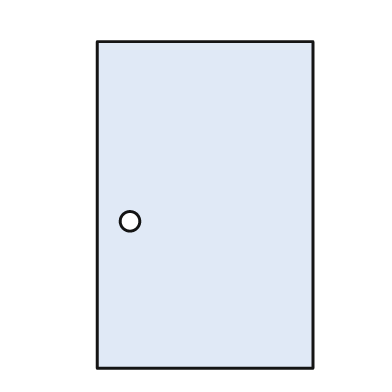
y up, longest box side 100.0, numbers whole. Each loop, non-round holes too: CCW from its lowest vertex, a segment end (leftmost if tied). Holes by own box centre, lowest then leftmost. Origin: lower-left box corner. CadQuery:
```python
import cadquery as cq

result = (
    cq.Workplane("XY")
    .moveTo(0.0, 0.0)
    .lineTo(66.0, 0.0)
    .lineTo(66.0, 100.0)
    .lineTo(0.0, 100.0)
    .close()
    .moveTo(10.0, 45.0)
    .circle(3.0)
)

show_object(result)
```